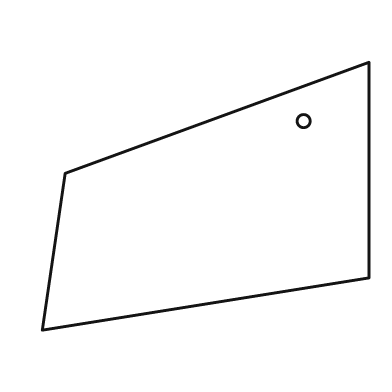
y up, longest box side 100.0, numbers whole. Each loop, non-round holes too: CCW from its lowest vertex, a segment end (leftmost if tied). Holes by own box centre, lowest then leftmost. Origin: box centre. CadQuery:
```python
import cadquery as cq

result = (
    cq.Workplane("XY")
    .moveTo(-50.0, -41.0)
    .lineTo(50.0, -25.0)
    .lineTo(50.0, 41.0)
    .lineTo(-43.0, 7.0)
    .close()
    .moveTo(30.0, 23.0)
    .circle(2.0)
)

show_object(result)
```